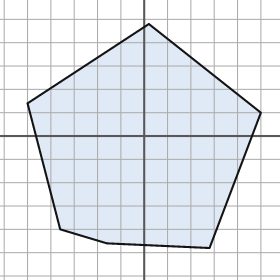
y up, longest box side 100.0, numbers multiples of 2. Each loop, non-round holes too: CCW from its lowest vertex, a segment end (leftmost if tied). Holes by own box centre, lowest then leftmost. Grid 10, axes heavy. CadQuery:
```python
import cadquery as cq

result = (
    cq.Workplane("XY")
    .moveTo(28.0, -48.0)
    .lineTo(50.0, 10.0)
    .lineTo(2.0, 48.0)
    .lineTo(-50.0, 14.0)
    .lineTo(-36.0, -40.0)
    .lineTo(-16.0, -46.0)
    .close()
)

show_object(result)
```